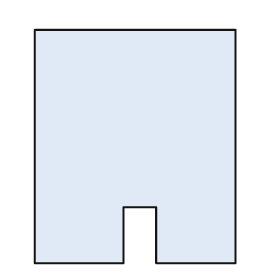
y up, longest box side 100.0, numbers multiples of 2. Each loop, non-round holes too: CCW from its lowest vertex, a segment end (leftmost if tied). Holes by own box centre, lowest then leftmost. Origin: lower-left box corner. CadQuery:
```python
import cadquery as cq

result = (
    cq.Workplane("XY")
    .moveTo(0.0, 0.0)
    .lineTo(38.0, 0.0)
    .lineTo(38.0, 24.0)
    .lineTo(52.0, 24.0)
    .lineTo(52.0, 0.0)
    .lineTo(86.0, 0.0)
    .lineTo(86.0, 100.0)
    .lineTo(0.0, 100.0)
    .close()
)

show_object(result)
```